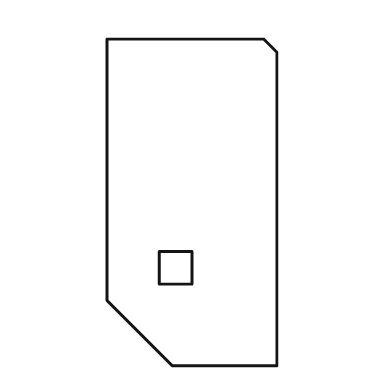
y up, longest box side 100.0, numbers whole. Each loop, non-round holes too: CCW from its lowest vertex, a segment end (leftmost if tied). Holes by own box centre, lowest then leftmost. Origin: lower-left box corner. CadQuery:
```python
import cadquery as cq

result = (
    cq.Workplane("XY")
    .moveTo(20.0, 0.0)
    .lineTo(52.0, 0.0)
    .lineTo(52.0, 96.0)
    .lineTo(48.0, 100.0)
    .lineTo(0.0, 100.0)
    .lineTo(0.0, 20.0)
    .close()
    .moveTo(16.0, 25.0)
    .lineTo(26.0, 25.0)
    .lineTo(26.0, 35.0)
    .lineTo(16.0, 35.0)
    .close()
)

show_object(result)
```